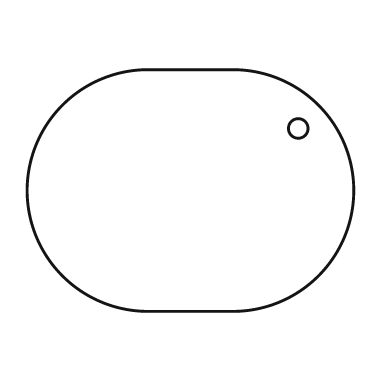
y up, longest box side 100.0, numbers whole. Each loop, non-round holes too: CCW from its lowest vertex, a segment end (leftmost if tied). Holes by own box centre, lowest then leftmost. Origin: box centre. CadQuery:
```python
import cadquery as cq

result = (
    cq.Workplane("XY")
    .moveTo(-13.0, -37.0)
    .lineTo(13.0, -37.0)
    .threePointArc((50.0, 0.0), (13.0, 37.0))
    .lineTo(-13.0, 37.0)
    .threePointArc((-50.0, 0.0), (-13.0, -37.0))
    .close()
    .moveTo(33.0, 19.0)
    .circle(3.0)
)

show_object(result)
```